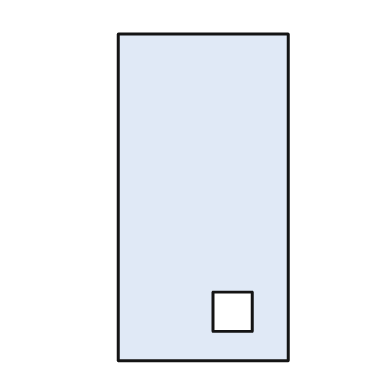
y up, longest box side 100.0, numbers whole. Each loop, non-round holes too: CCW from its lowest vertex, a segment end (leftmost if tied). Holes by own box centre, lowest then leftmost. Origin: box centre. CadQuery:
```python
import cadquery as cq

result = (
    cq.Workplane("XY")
    .moveTo(-26.0, -50.0)
    .lineTo(26.0, -50.0)
    .lineTo(26.0, 50.0)
    .lineTo(-26.0, 50.0)
    .close()
    .moveTo(3.0, -41.0)
    .lineTo(15.0, -41.0)
    .lineTo(15.0, -29.0)
    .lineTo(3.0, -29.0)
    .close()
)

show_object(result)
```